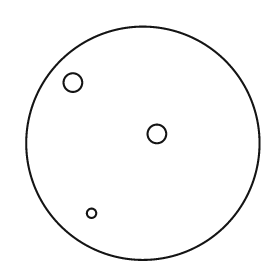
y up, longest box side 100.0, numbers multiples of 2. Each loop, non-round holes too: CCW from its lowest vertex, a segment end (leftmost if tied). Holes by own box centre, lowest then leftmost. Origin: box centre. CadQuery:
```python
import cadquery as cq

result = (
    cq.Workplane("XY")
    .moveTo(0.0, 0.0)
    .circle(50.0)
    .moveTo(-22.0, -30.0)
    .circle(2.0)
    .moveTo(6.0, 4.0)
    .circle(4.0)
    .moveTo(-30.0, 26.0)
    .circle(4.0)
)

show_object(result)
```